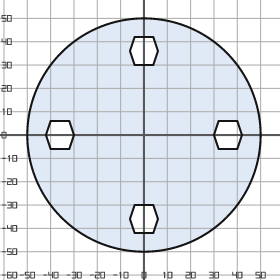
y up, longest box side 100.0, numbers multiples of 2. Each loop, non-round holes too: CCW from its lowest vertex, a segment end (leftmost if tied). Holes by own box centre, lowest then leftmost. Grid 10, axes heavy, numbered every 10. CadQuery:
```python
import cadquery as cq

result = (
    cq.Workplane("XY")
    .moveTo(0.0, 0.0)
    .circle(50.0)
    .moveTo(-4.0, -42.0)
    .lineTo(4.0, -42.0)
    .lineTo(6.0, -36.0)
    .lineTo(4.0, -30.0)
    .lineTo(-4.0, -30.0)
    .lineTo(-6.0, -36.0)
    .close()
    .moveTo(-40.0, -6.0)
    .lineTo(-32.0, -6.0)
    .lineTo(-30.0, 0.0)
    .lineTo(-32.0, 6.0)
    .lineTo(-40.0, 6.0)
    .lineTo(-42.0, 0.0)
    .close()
    .moveTo(32.0, -6.0)
    .lineTo(40.0, -6.0)
    .lineTo(42.0, 0.0)
    .lineTo(40.0, 6.0)
    .lineTo(32.0, 6.0)
    .lineTo(30.0, 0.0)
    .close()
    .moveTo(-4.0, 30.0)
    .lineTo(4.0, 30.0)
    .lineTo(6.0, 36.0)
    .lineTo(4.0, 42.0)
    .lineTo(-4.0, 42.0)
    .lineTo(-6.0, 36.0)
    .close()
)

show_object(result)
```